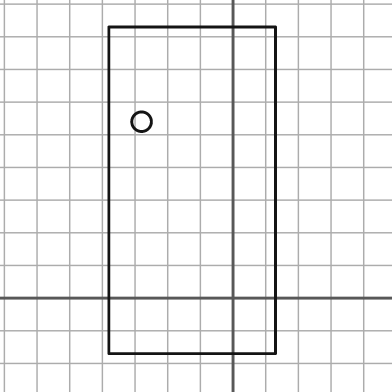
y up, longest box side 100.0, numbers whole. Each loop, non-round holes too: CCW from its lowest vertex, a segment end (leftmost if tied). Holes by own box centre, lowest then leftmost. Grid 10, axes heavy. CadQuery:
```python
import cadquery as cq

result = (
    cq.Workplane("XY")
    .moveTo(-38.0, -17.0)
    .lineTo(13.0, -17.0)
    .lineTo(13.0, 83.0)
    .lineTo(-38.0, 83.0)
    .close()
    .moveTo(-28.0, 54.0)
    .circle(3.0)
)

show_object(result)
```